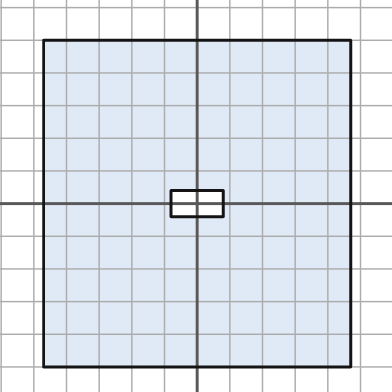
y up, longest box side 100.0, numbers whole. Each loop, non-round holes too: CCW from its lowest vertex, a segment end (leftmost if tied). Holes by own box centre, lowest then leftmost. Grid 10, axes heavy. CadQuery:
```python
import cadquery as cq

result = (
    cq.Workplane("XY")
    .moveTo(-47.0, -50.0)
    .lineTo(47.0, -50.0)
    .lineTo(47.0, 50.0)
    .lineTo(-47.0, 50.0)
    .close()
    .moveTo(-8.0, -4.0)
    .lineTo(8.0, -4.0)
    .lineTo(8.0, 4.0)
    .lineTo(-8.0, 4.0)
    .close()
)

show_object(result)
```